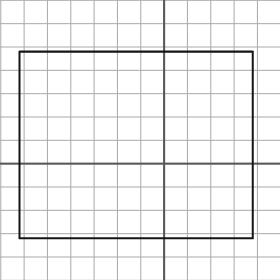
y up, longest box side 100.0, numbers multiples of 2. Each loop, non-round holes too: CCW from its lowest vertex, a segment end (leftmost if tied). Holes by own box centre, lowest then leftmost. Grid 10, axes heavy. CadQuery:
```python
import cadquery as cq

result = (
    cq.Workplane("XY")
    .moveTo(-62.0, -32.0)
    .lineTo(38.0, -32.0)
    .lineTo(38.0, 48.0)
    .lineTo(-62.0, 48.0)
    .close()
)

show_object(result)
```